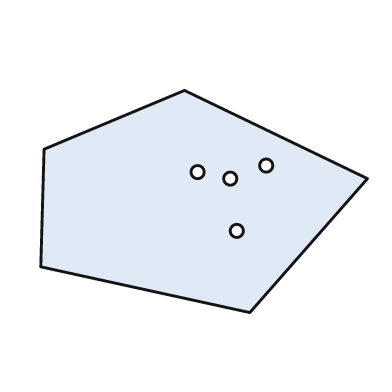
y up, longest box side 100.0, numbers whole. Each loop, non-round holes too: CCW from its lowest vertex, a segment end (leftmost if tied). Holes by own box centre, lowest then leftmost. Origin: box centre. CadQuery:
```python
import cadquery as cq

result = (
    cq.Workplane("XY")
    .moveTo(14.0, -34.0)
    .lineTo(50.0, 7.0)
    .lineTo(-6.0, 34.0)
    .lineTo(-49.0, 16.0)
    .lineTo(-50.0, -20.0)
    .close()
    .moveTo(10.0, -9.0)
    .circle(2.0)
    .moveTo(8.0, 7.0)
    .circle(2.0)
    .moveTo(-2.0, 9.0)
    .circle(2.0)
    .moveTo(19.0, 11.0)
    .circle(2.0)
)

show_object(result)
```